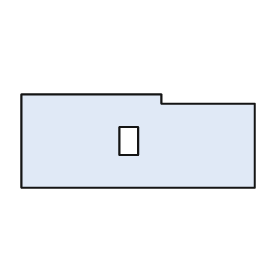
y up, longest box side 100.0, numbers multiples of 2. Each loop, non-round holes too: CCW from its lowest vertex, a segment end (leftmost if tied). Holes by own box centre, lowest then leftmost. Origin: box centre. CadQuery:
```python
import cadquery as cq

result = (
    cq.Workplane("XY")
    .moveTo(-50.0, -20.0)
    .lineTo(50.0, -20.0)
    .lineTo(50.0, 16.0)
    .lineTo(10.0, 16.0)
    .lineTo(10.0, 20.0)
    .lineTo(-50.0, 20.0)
    .close()
    .moveTo(-8.0, -6.0)
    .lineTo(0.0, -6.0)
    .lineTo(0.0, 6.0)
    .lineTo(-8.0, 6.0)
    .close()
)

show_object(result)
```